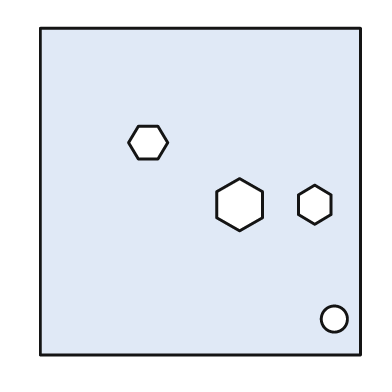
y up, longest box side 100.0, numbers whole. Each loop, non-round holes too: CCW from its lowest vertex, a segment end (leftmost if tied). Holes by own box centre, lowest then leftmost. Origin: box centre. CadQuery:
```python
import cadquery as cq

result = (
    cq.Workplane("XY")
    .moveTo(-49.0, -50.0)
    .lineTo(49.0, -50.0)
    .lineTo(49.0, 50.0)
    .lineTo(-49.0, 50.0)
    .close()
    .moveTo(41.0, -39.0)
    .circle(4.0)
    .moveTo(12.0, -12.0)
    .lineTo(19.0, -8.0)
    .lineTo(19.0, 0.0)
    .lineTo(12.0, 4.0)
    .lineTo(5.0, 0.0)
    .lineTo(5.0, -8.0)
    .close()
    .moveTo(35.0, -10.0)
    .lineTo(40.0, -7.0)
    .lineTo(40.0, -1.0)
    .lineTo(35.0, 2.0)
    .lineTo(30.0, -1.0)
    .lineTo(30.0, -7.0)
    .close()
    .moveTo(-19.0, 10.0)
    .lineTo(-13.0, 10.0)
    .lineTo(-10.0, 15.0)
    .lineTo(-13.0, 20.0)
    .lineTo(-19.0, 20.0)
    .lineTo(-22.0, 15.0)
    .close()
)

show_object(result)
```